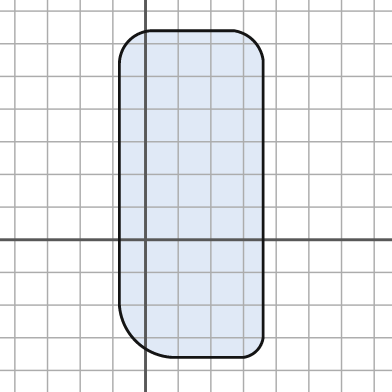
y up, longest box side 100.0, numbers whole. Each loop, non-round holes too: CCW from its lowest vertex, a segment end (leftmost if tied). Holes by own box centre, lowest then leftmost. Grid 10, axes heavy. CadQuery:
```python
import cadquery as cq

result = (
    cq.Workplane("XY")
    .moveTo(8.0, -36.0)
    .lineTo(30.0, -36.0)
    .threePointArc((34.0, -34.0), (36.0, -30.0))
    .lineTo(36.0, 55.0)
    .threePointArc((33.0, 61.0), (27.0, 64.0))
    .lineTo(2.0, 64.0)
    .threePointArc((-5.0, 61.0), (-8.0, 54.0))
    .lineTo(-8.0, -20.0)
    .threePointArc((-3.0, -31.0), (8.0, -36.0))
    .close()
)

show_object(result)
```